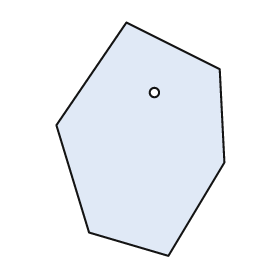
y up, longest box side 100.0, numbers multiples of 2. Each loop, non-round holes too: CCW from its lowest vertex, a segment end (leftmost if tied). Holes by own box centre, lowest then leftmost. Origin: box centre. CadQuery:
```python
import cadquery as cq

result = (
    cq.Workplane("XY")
    .moveTo(12.0, -50.0)
    .lineTo(36.0, -10.0)
    .lineTo(34.0, 30.0)
    .lineTo(-6.0, 50.0)
    .lineTo(-36.0, 6.0)
    .lineTo(-22.0, -40.0)
    .close()
    .moveTo(6.0, 20.0)
    .circle(2.0)
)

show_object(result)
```